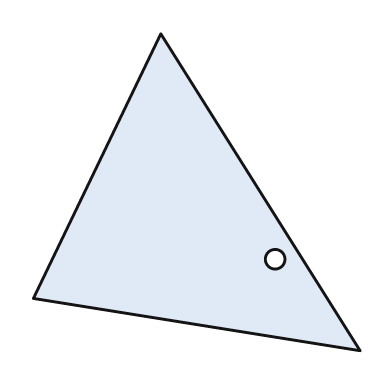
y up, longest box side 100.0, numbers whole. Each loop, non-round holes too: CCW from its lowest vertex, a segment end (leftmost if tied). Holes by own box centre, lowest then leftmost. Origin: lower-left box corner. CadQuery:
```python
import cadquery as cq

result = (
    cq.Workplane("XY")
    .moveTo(100.0, 0.0)
    .lineTo(39.0, 97.0)
    .lineTo(0.0, 16.0)
    .close()
    .moveTo(74.0, 28.0)
    .circle(3.0)
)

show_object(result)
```